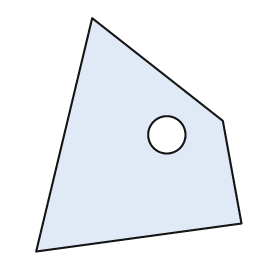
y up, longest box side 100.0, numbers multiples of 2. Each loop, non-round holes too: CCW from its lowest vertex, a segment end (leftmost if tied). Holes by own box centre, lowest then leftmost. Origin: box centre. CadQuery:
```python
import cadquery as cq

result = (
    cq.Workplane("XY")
    .moveTo(-44.0, -50.0)
    .lineTo(44.0, -38.0)
    .lineTo(36.0, 6.0)
    .lineTo(-20.0, 50.0)
    .close()
    .moveTo(12.0, 0.0)
    .circle(8.0)
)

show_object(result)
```